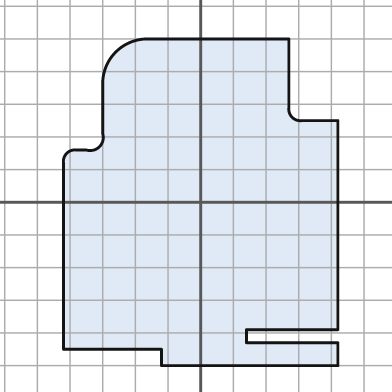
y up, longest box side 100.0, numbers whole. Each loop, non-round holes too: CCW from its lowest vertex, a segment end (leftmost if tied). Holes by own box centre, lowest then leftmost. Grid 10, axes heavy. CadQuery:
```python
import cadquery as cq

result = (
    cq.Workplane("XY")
    .moveTo(-12.0, -50.0)
    .lineTo(42.0, -50.0)
    .lineTo(42.0, -43.0)
    .lineTo(14.0, -43.0)
    .lineTo(14.0, -39.0)
    .lineTo(42.0, -39.0)
    .lineTo(42.0, 25.0)
    .lineTo(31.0, 25.0)
    .threePointArc((28.0, 26.0), (27.0, 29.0))
    .lineTo(27.0, 50.0)
    .lineTo(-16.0, 50.0)
    .threePointArc((-26.0, 46.0), (-30.0, 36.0))
    .lineTo(-30.0, 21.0)
    .threePointArc((-31.0, 17.0), (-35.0, 16.0))
    .lineTo(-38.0, 16.0)
    .threePointArc((-41.0, 15.0), (-42.0, 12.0))
    .lineTo(-42.0, -45.0)
    .lineTo(-12.0, -45.0)
    .close()
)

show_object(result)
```